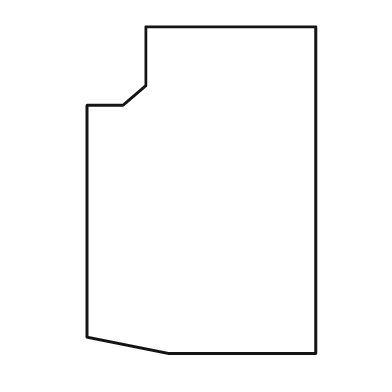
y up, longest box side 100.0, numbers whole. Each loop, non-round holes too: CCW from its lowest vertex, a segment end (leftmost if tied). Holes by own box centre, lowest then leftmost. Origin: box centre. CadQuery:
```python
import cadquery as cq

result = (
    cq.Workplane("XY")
    .moveTo(-10.0, -50.0)
    .lineTo(35.0, -50.0)
    .lineTo(35.0, 50.0)
    .lineTo(-17.0, 50.0)
    .lineTo(-17.0, 32.0)
    .lineTo(-24.0, 26.0)
    .lineTo(-35.0, 26.0)
    .lineTo(-35.0, -45.0)
    .close()
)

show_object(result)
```